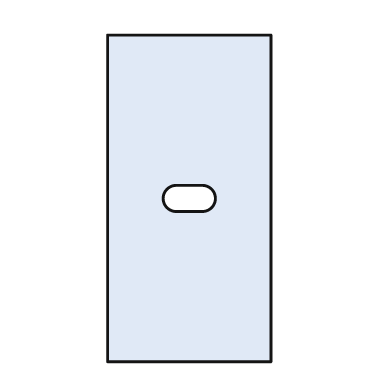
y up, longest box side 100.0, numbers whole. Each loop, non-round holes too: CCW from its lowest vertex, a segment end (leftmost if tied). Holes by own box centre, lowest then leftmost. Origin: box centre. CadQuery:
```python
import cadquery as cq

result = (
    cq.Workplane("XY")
    .moveTo(-25.0, -50.0)
    .lineTo(25.0, -50.0)
    .lineTo(25.0, 50.0)
    .lineTo(-25.0, 50.0)
    .close()
    .moveTo(-4.0, -4.0)
    .lineTo(4.0, -4.0)
    .threePointArc((8.0, 0.0), (4.0, 4.0))
    .lineTo(-4.0, 4.0)
    .threePointArc((-8.0, 0.0), (-4.0, -4.0))
    .close()
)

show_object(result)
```